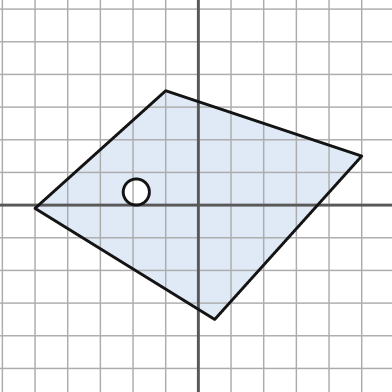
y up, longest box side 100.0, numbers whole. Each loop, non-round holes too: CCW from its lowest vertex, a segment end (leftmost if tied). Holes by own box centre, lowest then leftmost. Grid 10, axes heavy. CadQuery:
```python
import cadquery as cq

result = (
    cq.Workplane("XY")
    .moveTo(5.0, -35.0)
    .lineTo(50.0, 15.0)
    .lineTo(-10.0, 35.0)
    .lineTo(-50.0, -1.0)
    .close()
    .moveTo(-19.0, 4.0)
    .circle(4.0)
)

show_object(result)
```